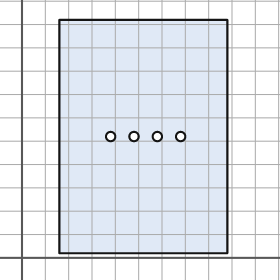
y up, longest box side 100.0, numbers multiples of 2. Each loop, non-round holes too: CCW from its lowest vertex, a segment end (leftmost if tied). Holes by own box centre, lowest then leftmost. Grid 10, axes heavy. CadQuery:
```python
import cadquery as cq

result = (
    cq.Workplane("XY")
    .moveTo(16.0, 2.0)
    .lineTo(88.0, 2.0)
    .lineTo(88.0, 102.0)
    .lineTo(16.0, 102.0)
    .close()
    .moveTo(38.0, 52.0)
    .circle(2.0)
    .moveTo(48.0, 52.0)
    .circle(2.0)
    .moveTo(58.0, 52.0)
    .circle(2.0)
    .moveTo(68.0, 52.0)
    .circle(2.0)
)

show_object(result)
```